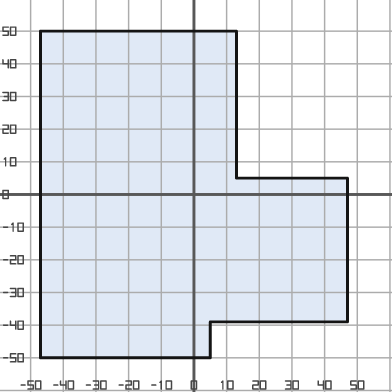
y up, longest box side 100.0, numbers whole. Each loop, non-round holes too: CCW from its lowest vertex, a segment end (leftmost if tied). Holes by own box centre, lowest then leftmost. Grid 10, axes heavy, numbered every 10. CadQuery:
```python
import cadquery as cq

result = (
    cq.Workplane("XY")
    .moveTo(-47.0, -50.0)
    .lineTo(5.0, -50.0)
    .lineTo(5.0, -39.0)
    .lineTo(47.0, -39.0)
    .lineTo(47.0, 5.0)
    .lineTo(13.0, 5.0)
    .lineTo(13.0, 50.0)
    .lineTo(-47.0, 50.0)
    .close()
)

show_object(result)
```